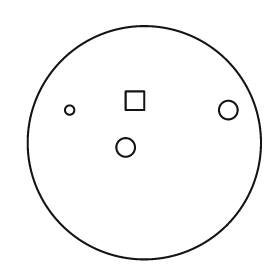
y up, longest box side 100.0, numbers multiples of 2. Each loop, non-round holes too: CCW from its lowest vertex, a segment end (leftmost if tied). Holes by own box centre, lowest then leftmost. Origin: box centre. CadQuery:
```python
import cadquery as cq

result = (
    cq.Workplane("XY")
    .moveTo(0.0, 0.0)
    .circle(50.0)
    .moveTo(-8.0, -2.0)
    .circle(4.0)
    .moveTo(-32.0, 14.0)
    .circle(2.0)
    .moveTo(36.0, 14.0)
    .circle(4.0)
    .moveTo(-8.0, 14.0)
    .lineTo(0.0, 14.0)
    .lineTo(0.0, 22.0)
    .lineTo(-8.0, 22.0)
    .close()
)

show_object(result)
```